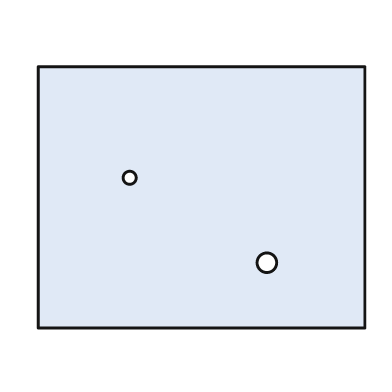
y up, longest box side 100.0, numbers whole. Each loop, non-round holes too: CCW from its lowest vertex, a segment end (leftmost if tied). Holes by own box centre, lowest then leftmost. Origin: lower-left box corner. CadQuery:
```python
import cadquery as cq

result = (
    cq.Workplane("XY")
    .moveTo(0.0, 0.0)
    .lineTo(100.0, 0.0)
    .lineTo(100.0, 80.0)
    .lineTo(0.0, 80.0)
    .close()
    .moveTo(70.0, 20.0)
    .circle(3.0)
    .moveTo(28.0, 46.0)
    .circle(2.0)
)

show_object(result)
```